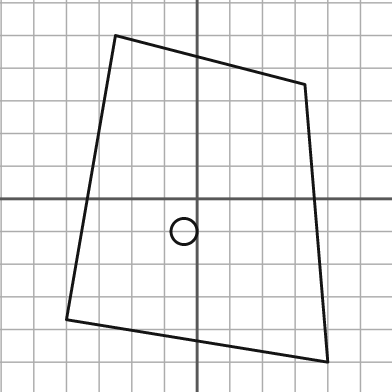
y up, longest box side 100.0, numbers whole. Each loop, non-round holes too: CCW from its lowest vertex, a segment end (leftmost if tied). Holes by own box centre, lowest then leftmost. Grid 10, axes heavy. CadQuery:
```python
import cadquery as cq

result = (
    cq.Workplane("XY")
    .moveTo(40.0, -50.0)
    .lineTo(33.0, 35.0)
    .lineTo(-25.0, 50.0)
    .lineTo(-40.0, -37.0)
    .close()
    .moveTo(-4.0, -10.0)
    .circle(4.0)
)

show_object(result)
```